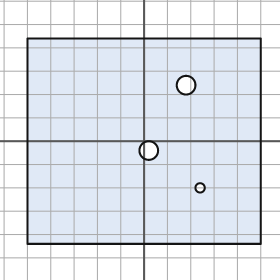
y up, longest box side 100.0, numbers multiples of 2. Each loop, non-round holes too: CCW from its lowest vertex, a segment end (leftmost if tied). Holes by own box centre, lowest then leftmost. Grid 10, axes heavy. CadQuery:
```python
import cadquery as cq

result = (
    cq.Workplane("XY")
    .moveTo(-50.0, -44.0)
    .lineTo(50.0, -44.0)
    .lineTo(50.0, 44.0)
    .lineTo(-50.0, 44.0)
    .close()
    .moveTo(24.0, -20.0)
    .circle(2.0)
    .moveTo(2.0, -4.0)
    .circle(4.0)
    .moveTo(18.0, 24.0)
    .circle(4.0)
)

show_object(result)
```